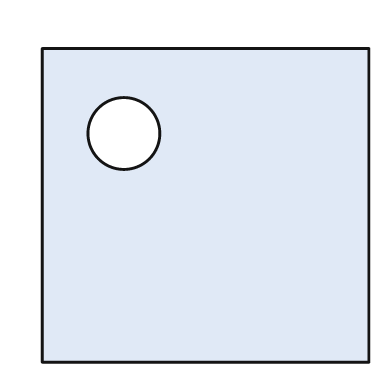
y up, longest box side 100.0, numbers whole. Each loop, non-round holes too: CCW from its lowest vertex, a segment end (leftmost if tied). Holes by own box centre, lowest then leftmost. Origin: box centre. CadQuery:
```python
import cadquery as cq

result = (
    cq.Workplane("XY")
    .moveTo(-50.0, -48.0)
    .lineTo(50.0, -48.0)
    .lineTo(50.0, 48.0)
    .lineTo(-50.0, 48.0)
    .close()
    .moveTo(-25.0, 22.0)
    .circle(11.0)
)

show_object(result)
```